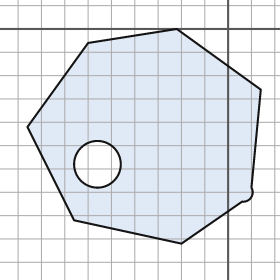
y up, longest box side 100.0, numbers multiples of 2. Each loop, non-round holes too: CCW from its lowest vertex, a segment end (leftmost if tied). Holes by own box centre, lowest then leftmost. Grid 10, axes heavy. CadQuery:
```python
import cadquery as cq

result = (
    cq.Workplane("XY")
    .moveTo(-20.0, -92.0)
    .lineTo(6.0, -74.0)
    .threePointArc((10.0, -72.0), (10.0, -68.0))
    .lineTo(14.0, -26.0)
    .lineTo(-22.0, 0.0)
    .lineTo(-60.0, -6.0)
    .lineTo(-86.0, -42.0)
    .lineTo(-66.0, -82.0)
    .close()
    .moveTo(-56.0, -58.0)
    .circle(10.0)
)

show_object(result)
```